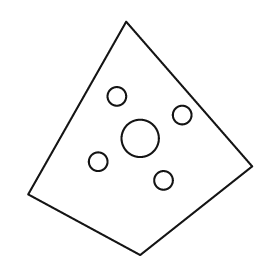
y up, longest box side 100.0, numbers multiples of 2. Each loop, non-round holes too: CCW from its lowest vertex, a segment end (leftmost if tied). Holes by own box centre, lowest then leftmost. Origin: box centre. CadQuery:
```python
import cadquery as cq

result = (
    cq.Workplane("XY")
    .moveTo(0.0, -50.0)
    .lineTo(48.0, -12.0)
    .lineTo(-6.0, 50.0)
    .lineTo(-48.0, -24.0)
    .close()
    .moveTo(10.0, -18.0)
    .circle(4.0)
    .moveTo(-18.0, -10.0)
    .circle(4.0)
    .moveTo(0.0, 0.0)
    .circle(8.0)
    .moveTo(18.0, 10.0)
    .circle(4.0)
    .moveTo(-10.0, 18.0)
    .circle(4.0)
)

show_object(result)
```